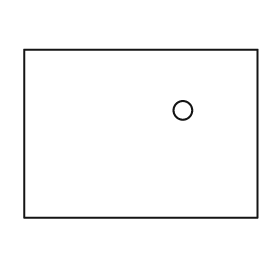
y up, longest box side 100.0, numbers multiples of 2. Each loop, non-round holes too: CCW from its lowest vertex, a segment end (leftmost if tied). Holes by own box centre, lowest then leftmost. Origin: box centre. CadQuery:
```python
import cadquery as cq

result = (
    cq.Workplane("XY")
    .moveTo(-50.0, -36.0)
    .lineTo(50.0, -36.0)
    .lineTo(50.0, 36.0)
    .lineTo(-50.0, 36.0)
    .close()
    .moveTo(18.0, 10.0)
    .circle(4.0)
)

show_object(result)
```